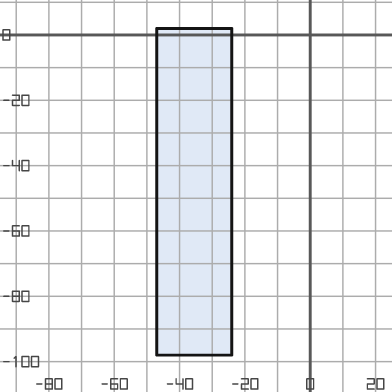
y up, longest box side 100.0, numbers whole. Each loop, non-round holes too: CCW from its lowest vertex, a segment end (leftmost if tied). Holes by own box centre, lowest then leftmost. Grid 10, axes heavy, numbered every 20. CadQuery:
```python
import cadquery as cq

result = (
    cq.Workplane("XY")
    .moveTo(-47.0, -98.0)
    .lineTo(-24.0, -98.0)
    .lineTo(-24.0, 2.0)
    .lineTo(-47.0, 2.0)
    .close()
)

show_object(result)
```